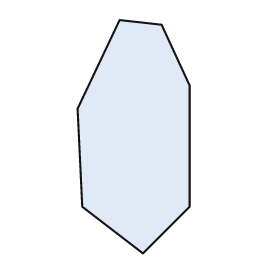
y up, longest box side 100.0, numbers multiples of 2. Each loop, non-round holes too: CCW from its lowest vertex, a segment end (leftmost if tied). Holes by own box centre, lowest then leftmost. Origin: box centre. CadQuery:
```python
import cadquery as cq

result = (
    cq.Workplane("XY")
    .moveTo(4.0, -50.0)
    .lineTo(24.0, -30.0)
    .lineTo(24.0, 22.0)
    .lineTo(12.0, 48.0)
    .lineTo(-6.0, 50.0)
    .lineTo(-24.0, 12.0)
    .lineTo(-22.0, -30.0)
    .close()
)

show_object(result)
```